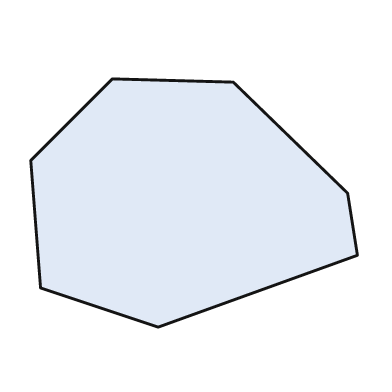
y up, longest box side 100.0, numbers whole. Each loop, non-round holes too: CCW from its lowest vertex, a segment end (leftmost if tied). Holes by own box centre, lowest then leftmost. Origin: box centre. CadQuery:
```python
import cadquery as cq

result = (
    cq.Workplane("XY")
    .moveTo(-11.0, -38.0)
    .lineTo(50.0, -16.0)
    .lineTo(47.0, 3.0)
    .lineTo(12.0, 37.0)
    .lineTo(-25.0, 38.0)
    .lineTo(-50.0, 13.0)
    .lineTo(-47.0, -26.0)
    .close()
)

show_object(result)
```